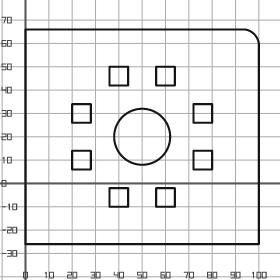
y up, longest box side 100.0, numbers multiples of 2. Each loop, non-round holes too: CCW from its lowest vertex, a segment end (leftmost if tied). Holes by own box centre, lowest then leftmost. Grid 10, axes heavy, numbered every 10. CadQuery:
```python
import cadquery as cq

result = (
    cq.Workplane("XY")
    .moveTo(0.0, -26.0)
    .lineTo(100.0, -26.0)
    .lineTo(100.0, 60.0)
    .threePointArc((98.0, 64.0), (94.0, 66.0))
    .lineTo(0.0, 66.0)
    .close()
    .moveTo(36.0, -10.0)
    .lineTo(44.0, -10.0)
    .lineTo(44.0, -2.0)
    .lineTo(36.0, -2.0)
    .close()
    .moveTo(56.0, -10.0)
    .lineTo(64.0, -10.0)
    .lineTo(64.0, -2.0)
    .lineTo(56.0, -2.0)
    .close()
    .moveTo(20.0, 6.0)
    .lineTo(28.0, 6.0)
    .lineTo(28.0, 14.0)
    .lineTo(20.0, 14.0)
    .close()
    .moveTo(72.0, 6.0)
    .lineTo(80.0, 6.0)
    .lineTo(80.0, 14.0)
    .lineTo(72.0, 14.0)
    .close()
    .moveTo(50.0, 20.0)
    .circle(12.0)
    .moveTo(20.0, 26.0)
    .lineTo(28.0, 26.0)
    .lineTo(28.0, 34.0)
    .lineTo(20.0, 34.0)
    .close()
    .moveTo(72.0, 26.0)
    .lineTo(80.0, 26.0)
    .lineTo(80.0, 34.0)
    .lineTo(72.0, 34.0)
    .close()
    .moveTo(36.0, 42.0)
    .lineTo(44.0, 42.0)
    .lineTo(44.0, 50.0)
    .lineTo(36.0, 50.0)
    .close()
    .moveTo(56.0, 42.0)
    .lineTo(64.0, 42.0)
    .lineTo(64.0, 50.0)
    .lineTo(56.0, 50.0)
    .close()
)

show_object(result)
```